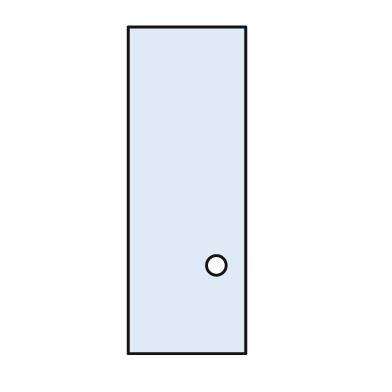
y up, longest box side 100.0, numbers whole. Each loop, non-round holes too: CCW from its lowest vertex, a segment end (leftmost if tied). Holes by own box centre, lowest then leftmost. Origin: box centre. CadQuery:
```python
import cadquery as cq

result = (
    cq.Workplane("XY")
    .moveTo(-18.0, -50.0)
    .lineTo(18.0, -50.0)
    .lineTo(18.0, 50.0)
    .lineTo(-18.0, 50.0)
    .close()
    .moveTo(9.0, -23.0)
    .circle(3.0)
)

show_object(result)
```